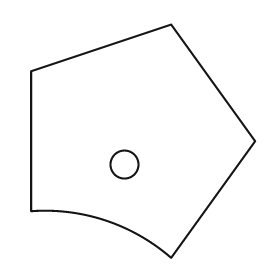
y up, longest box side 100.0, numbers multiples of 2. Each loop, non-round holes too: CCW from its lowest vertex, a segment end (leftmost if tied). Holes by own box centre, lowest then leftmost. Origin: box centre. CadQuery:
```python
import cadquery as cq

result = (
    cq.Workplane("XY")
    .moveTo(12.0, -50.0)
    .lineTo(48.0, 0.0)
    .lineTo(12.0, 50.0)
    .lineTo(-48.0, 30.0)
    .lineTo(-48.0, -30.0)
    .threePointArc((-16.0, -34.0), (12.0, -50.0))
    .close()
    .moveTo(-8.0, -10.0)
    .circle(6.0)
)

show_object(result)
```